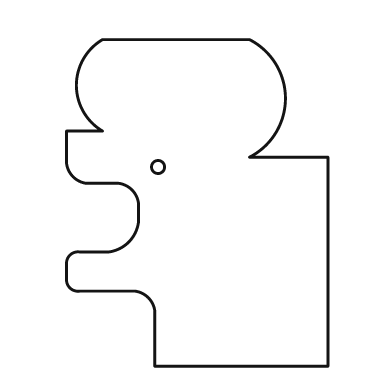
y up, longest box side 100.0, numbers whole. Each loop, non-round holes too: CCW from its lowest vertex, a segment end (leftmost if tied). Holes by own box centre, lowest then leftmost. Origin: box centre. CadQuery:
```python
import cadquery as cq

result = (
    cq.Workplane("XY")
    .moveTo(-13.0, -50.0)
    .lineTo(40.0, -50.0)
    .lineTo(40.0, 14.0)
    .lineTo(16.0, 14.0)
    .threePointArc((27.0, 32.0), (16.0, 50.0))
    .lineTo(-29.0, 50.0)
    .threePointArc((-37.0, 36.0), (-29.0, 22.0))
    .lineTo(-40.0, 22.0)
    .lineTo(-40.0, 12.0)
    .threePointArc((-38.0, 8.0), (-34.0, 6.0))
    .lineTo(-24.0, 6.0)
    .threePointArc((-20.0, 4.0), (-18.0, 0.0))
    .lineTo(-18.0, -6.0)
    .threePointArc((-21.0, -12.0), (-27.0, -15.0))
    .lineTo(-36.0, -15.0)
    .threePointArc((-39.0, -16.0), (-40.0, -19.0))
    .lineTo(-40.0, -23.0)
    .threePointArc((-39.0, -26.0), (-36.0, -27.0))
    .lineTo(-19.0, -27.0)
    .threePointArc((-15.0, -29.0), (-13.0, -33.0))
    .close()
    .moveTo(-12.0, 11.0)
    .circle(2.0)
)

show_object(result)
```